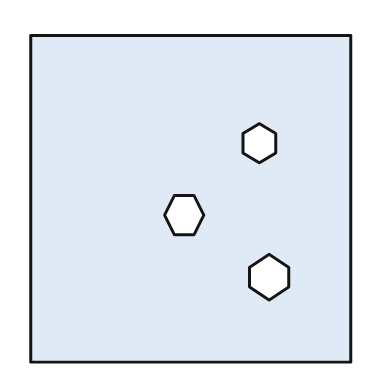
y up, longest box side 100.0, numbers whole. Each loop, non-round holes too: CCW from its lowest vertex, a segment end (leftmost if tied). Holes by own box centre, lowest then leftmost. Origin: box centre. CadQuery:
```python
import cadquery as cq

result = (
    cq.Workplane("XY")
    .moveTo(-49.0, -50.0)
    .lineTo(49.0, -50.0)
    .lineTo(49.0, 50.0)
    .lineTo(-49.0, 50.0)
    .close()
    .moveTo(24.0, -31.0)
    .lineTo(30.0, -27.0)
    .lineTo(30.0, -21.0)
    .lineTo(24.0, -17.0)
    .lineTo(18.0, -21.0)
    .lineTo(18.0, -27.0)
    .close()
    .moveTo(-5.0, -11.0)
    .lineTo(1.0, -11.0)
    .lineTo(4.0, -5.0)
    .lineTo(1.0, 1.0)
    .lineTo(-5.0, 1.0)
    .lineTo(-8.0, -5.0)
    .close()
    .moveTo(21.0, 11.0)
    .lineTo(26.0, 14.0)
    .lineTo(26.0, 20.0)
    .lineTo(21.0, 23.0)
    .lineTo(16.0, 20.0)
    .lineTo(16.0, 14.0)
    .close()
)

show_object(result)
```